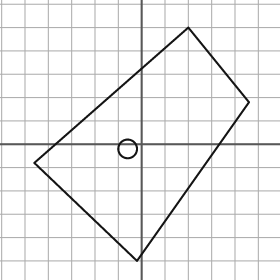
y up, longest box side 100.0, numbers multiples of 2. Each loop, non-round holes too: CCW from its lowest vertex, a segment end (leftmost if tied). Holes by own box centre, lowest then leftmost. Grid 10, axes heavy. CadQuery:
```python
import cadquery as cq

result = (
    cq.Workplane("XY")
    .moveTo(-2.0, -50.0)
    .lineTo(46.0, 18.0)
    .lineTo(20.0, 50.0)
    .lineTo(-46.0, -8.0)
    .close()
    .moveTo(-6.0, -2.0)
    .circle(4.0)
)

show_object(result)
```